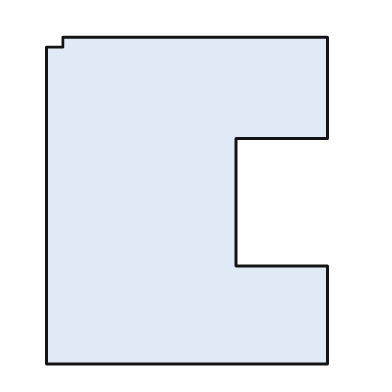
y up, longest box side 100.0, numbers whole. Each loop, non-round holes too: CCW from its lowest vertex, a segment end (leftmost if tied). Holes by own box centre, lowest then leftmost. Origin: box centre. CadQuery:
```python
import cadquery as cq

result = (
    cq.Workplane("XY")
    .moveTo(-43.0, -50.0)
    .lineTo(43.0, -50.0)
    .lineTo(43.0, -20.0)
    .lineTo(15.0, -20.0)
    .lineTo(15.0, 19.0)
    .lineTo(43.0, 19.0)
    .lineTo(43.0, 50.0)
    .lineTo(-38.0, 50.0)
    .lineTo(-38.0, 47.0)
    .lineTo(-43.0, 47.0)
    .close()
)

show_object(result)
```